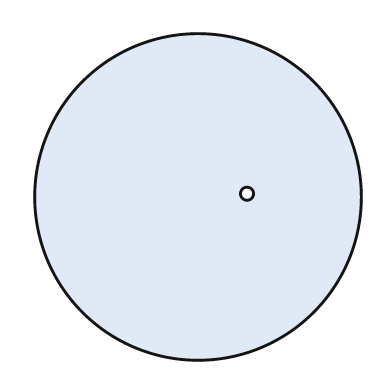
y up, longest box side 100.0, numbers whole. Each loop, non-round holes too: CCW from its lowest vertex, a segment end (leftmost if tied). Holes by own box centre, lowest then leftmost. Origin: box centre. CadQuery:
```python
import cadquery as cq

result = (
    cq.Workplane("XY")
    .moveTo(0.0, 0.0)
    .circle(50.0)
    .moveTo(15.0, 1.0)
    .circle(2.0)
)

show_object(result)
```